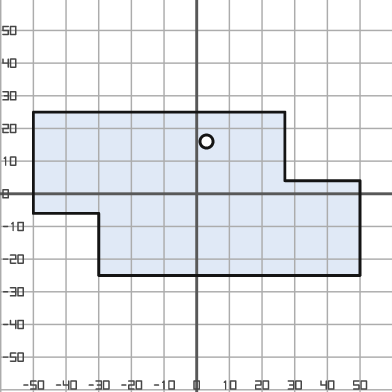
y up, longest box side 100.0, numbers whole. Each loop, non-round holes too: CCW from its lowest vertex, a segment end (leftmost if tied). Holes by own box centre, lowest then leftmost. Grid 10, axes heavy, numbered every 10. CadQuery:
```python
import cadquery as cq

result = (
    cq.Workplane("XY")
    .moveTo(-30.0, -25.0)
    .lineTo(50.0, -25.0)
    .lineTo(50.0, 4.0)
    .lineTo(27.0, 4.0)
    .lineTo(27.0, 25.0)
    .lineTo(-50.0, 25.0)
    .lineTo(-50.0, -6.0)
    .lineTo(-30.0, -6.0)
    .close()
    .moveTo(3.0, 16.0)
    .circle(2.0)
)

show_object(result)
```